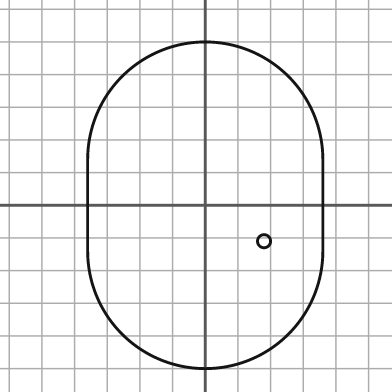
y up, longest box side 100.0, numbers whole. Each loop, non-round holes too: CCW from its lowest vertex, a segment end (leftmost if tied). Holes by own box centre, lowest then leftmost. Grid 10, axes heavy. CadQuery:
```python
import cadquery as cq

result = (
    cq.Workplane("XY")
    .moveTo(-36.0, -14.0)
    .threePointArc((0.0, -50.0), (36.0, -14.0))
    .lineTo(36.0, 14.0)
    .threePointArc((0.0, 50.0), (-36.0, 14.0))
    .close()
    .moveTo(18.0, -11.0)
    .circle(2.0)
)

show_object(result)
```